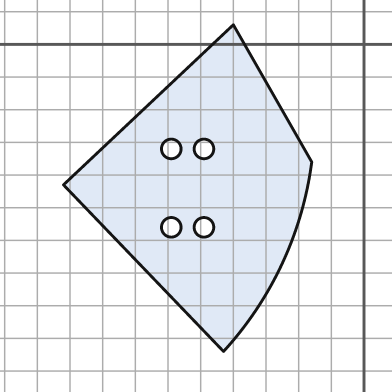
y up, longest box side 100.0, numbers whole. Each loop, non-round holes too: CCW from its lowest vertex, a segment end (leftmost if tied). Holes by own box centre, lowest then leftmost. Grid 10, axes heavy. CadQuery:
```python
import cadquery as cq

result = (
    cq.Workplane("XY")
    .moveTo(-43.0, -94.0)
    .threePointArc((-25.0, -67.0), (-16.0, -36.0))
    .lineTo(-40.0, 6.0)
    .lineTo(-92.0, -43.0)
    .close()
    .moveTo(-59.0, -56.0)
    .circle(3.0)
    .moveTo(-49.0, -56.0)
    .circle(3.0)
    .moveTo(-59.0, -32.0)
    .circle(3.0)
    .moveTo(-49.0, -32.0)
    .circle(3.0)
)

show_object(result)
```